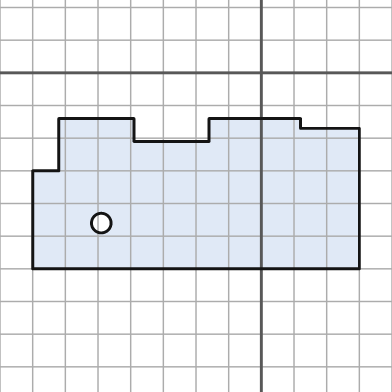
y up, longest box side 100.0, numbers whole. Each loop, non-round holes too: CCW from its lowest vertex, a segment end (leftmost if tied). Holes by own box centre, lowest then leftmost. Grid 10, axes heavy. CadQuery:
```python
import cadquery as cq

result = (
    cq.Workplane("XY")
    .moveTo(-70.0, -60.0)
    .lineTo(30.0, -60.0)
    .lineTo(30.0, -17.0)
    .lineTo(12.0, -17.0)
    .lineTo(12.0, -14.0)
    .lineTo(-16.0, -14.0)
    .lineTo(-16.0, -21.0)
    .lineTo(-39.0, -21.0)
    .lineTo(-39.0, -14.0)
    .lineTo(-62.0, -14.0)
    .lineTo(-62.0, -30.0)
    .lineTo(-70.0, -30.0)
    .close()
    .moveTo(-49.0, -46.0)
    .circle(3.0)
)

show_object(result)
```